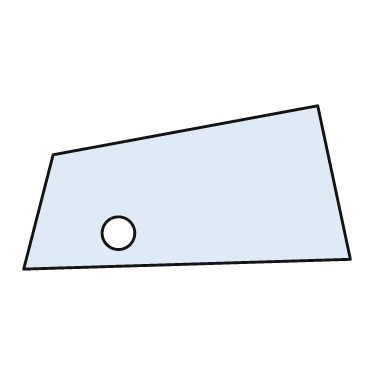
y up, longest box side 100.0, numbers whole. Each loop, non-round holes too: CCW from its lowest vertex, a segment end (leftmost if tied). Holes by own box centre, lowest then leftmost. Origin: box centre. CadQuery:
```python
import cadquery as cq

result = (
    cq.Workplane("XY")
    .moveTo(-50.0, -25.0)
    .lineTo(50.0, -22.0)
    .lineTo(40.0, 25.0)
    .lineTo(-41.0, 10.0)
    .close()
    .moveTo(-21.0, -14.0)
    .circle(5.0)
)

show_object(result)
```